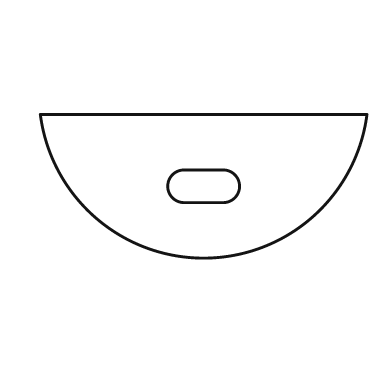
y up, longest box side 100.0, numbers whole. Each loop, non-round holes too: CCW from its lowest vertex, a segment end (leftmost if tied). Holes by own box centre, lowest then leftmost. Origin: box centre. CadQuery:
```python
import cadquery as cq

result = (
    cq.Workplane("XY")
    .moveTo(-50.0, 22.0)
    .threePointArc((0.0, -22.0), (50.0, 22.0))
    .close()
    .moveTo(-6.0, -5.0)
    .lineTo(6.0, -5.0)
    .threePointArc((11.0, 0.0), (6.0, 5.0))
    .lineTo(-6.0, 5.0)
    .threePointArc((-11.0, 0.0), (-6.0, -5.0))
    .close()
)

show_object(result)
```